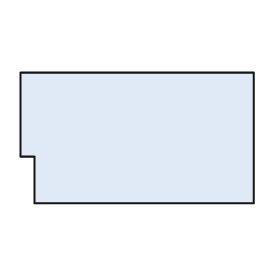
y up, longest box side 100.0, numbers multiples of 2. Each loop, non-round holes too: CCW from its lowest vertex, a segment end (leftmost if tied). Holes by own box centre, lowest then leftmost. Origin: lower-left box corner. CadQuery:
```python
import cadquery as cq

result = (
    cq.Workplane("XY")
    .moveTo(6.0, 0.0)
    .lineTo(100.0, 0.0)
    .lineTo(100.0, 56.0)
    .lineTo(0.0, 56.0)
    .lineTo(0.0, 20.0)
    .lineTo(6.0, 20.0)
    .close()
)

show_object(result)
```